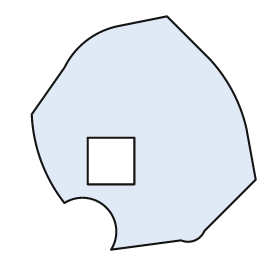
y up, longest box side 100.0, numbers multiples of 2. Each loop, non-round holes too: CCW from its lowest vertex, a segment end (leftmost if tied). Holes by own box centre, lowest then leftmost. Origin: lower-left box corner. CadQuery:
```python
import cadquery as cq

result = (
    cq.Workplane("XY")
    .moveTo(34.0, 0.0)
    .lineTo(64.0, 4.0)
    .threePointArc((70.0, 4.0), (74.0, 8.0))
    .lineTo(96.0, 30.0)
    .lineTo(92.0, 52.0)
    .threePointArc((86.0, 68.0), (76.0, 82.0))
    .lineTo(58.0, 100.0)
    .lineTo(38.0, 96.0)
    .threePointArc((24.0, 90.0), (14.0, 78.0))
    .lineTo(0.0, 58.0)
    .threePointArc((4.0, 38.0), (14.0, 20.0))
    .threePointArc((32.0, 18.0), (34.0, 0.0))
    .close()
    .moveTo(24.0, 28.0)
    .lineTo(44.0, 28.0)
    .lineTo(44.0, 48.0)
    .lineTo(24.0, 48.0)
    .close()
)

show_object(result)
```